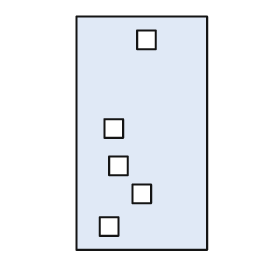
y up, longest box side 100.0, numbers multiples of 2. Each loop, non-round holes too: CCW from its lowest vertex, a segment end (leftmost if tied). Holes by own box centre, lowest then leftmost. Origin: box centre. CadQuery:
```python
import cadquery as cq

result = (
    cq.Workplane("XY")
    .moveTo(-28.0, -50.0)
    .lineTo(28.0, -50.0)
    .lineTo(28.0, 50.0)
    .lineTo(-28.0, 50.0)
    .close()
    .moveTo(-18.0, -44.0)
    .lineTo(-10.0, -44.0)
    .lineTo(-10.0, -36.0)
    .lineTo(-18.0, -36.0)
    .close()
    .moveTo(-4.0, -30.0)
    .lineTo(4.0, -30.0)
    .lineTo(4.0, -22.0)
    .lineTo(-4.0, -22.0)
    .close()
    .moveTo(-14.0, -18.0)
    .lineTo(-6.0, -18.0)
    .lineTo(-6.0, -10.0)
    .lineTo(-14.0, -10.0)
    .close()
    .moveTo(-16.0, -2.0)
    .lineTo(-8.0, -2.0)
    .lineTo(-8.0, 6.0)
    .lineTo(-16.0, 6.0)
    .close()
    .moveTo(-2.0, 36.0)
    .lineTo(6.0, 36.0)
    .lineTo(6.0, 44.0)
    .lineTo(-2.0, 44.0)
    .close()
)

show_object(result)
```